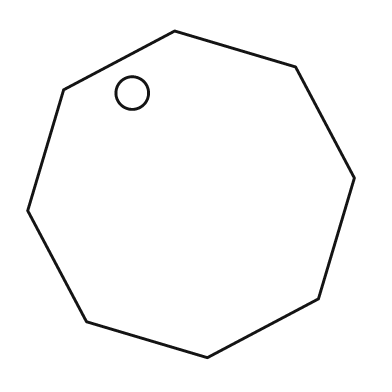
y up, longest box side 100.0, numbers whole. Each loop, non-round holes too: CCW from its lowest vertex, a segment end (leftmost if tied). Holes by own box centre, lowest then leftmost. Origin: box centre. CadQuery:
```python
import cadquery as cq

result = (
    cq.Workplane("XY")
    .moveTo(5.0, -50.0)
    .lineTo(39.0, -32.0)
    .lineTo(50.0, 5.0)
    .lineTo(32.0, 39.0)
    .lineTo(-5.0, 50.0)
    .lineTo(-39.0, 32.0)
    .lineTo(-50.0, -5.0)
    .lineTo(-32.0, -39.0)
    .close()
    .moveTo(-18.0, 31.0)
    .circle(5.0)
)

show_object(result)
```